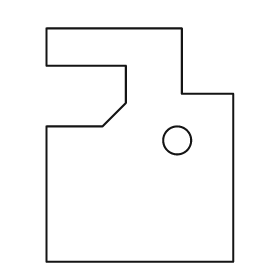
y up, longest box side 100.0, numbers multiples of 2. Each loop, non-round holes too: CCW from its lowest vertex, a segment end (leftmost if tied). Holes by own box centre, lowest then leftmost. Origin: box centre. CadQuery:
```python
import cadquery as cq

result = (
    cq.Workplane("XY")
    .moveTo(-40.0, -50.0)
    .lineTo(40.0, -50.0)
    .lineTo(40.0, 22.0)
    .lineTo(18.0, 22.0)
    .lineTo(18.0, 50.0)
    .lineTo(-40.0, 50.0)
    .lineTo(-40.0, 34.0)
    .lineTo(-6.0, 34.0)
    .lineTo(-6.0, 18.0)
    .lineTo(-16.0, 8.0)
    .lineTo(-40.0, 8.0)
    .close()
    .moveTo(16.0, 2.0)
    .circle(6.0)
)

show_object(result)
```